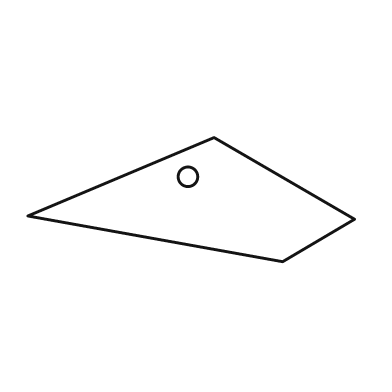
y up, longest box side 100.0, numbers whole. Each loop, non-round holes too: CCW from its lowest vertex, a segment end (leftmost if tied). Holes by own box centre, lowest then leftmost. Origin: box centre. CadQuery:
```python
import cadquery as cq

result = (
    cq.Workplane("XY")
    .moveTo(28.0, -19.0)
    .lineTo(50.0, -6.0)
    .lineTo(7.0, 19.0)
    .lineTo(-50.0, -5.0)
    .close()
    .moveTo(-1.0, 7.0)
    .circle(3.0)
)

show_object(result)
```